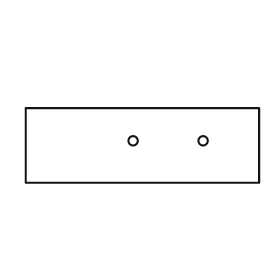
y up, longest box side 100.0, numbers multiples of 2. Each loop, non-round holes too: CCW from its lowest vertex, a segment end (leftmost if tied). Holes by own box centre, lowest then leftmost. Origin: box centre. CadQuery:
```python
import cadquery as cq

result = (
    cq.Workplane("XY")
    .moveTo(-50.0, -16.0)
    .lineTo(50.0, -16.0)
    .lineTo(50.0, 16.0)
    .lineTo(-50.0, 16.0)
    .close()
    .moveTo(-4.0, 2.0)
    .circle(2.0)
    .moveTo(26.0, 2.0)
    .circle(2.0)
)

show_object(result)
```